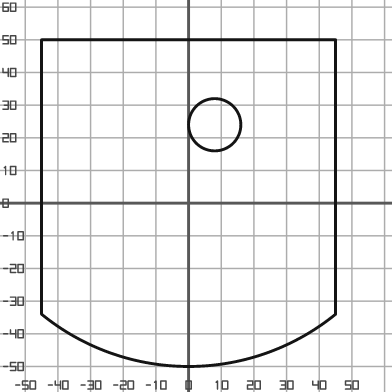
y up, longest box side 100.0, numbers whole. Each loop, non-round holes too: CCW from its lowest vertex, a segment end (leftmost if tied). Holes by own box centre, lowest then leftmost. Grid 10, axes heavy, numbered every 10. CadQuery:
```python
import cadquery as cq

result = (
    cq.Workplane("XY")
    .moveTo(-45.0, -34.0)
    .threePointArc((0.0, -50.0), (45.0, -34.0))
    .lineTo(45.0, 50.0)
    .lineTo(-45.0, 50.0)
    .close()
    .moveTo(8.0, 24.0)
    .circle(8.0)
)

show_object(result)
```